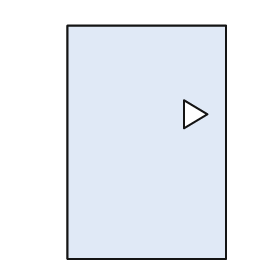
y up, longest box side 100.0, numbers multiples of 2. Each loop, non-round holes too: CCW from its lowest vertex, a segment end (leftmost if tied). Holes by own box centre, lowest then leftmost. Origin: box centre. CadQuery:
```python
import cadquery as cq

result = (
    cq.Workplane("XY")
    .moveTo(-34.0, -50.0)
    .lineTo(34.0, -50.0)
    .lineTo(34.0, 50.0)
    .lineTo(-34.0, 50.0)
    .close()
    .moveTo(16.0, 6.0)
    .lineTo(26.0, 12.0)
    .lineTo(16.0, 18.0)
    .close()
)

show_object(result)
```